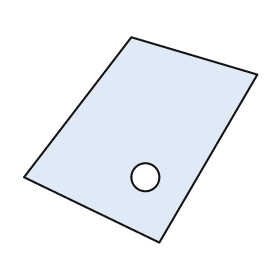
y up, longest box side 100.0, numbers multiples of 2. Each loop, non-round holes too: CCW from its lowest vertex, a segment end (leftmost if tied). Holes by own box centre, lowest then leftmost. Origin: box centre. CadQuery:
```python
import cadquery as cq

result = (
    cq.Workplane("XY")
    .moveTo(8.0, -44.0)
    .lineTo(50.0, 28.0)
    .lineTo(-4.0, 44.0)
    .lineTo(-50.0, -16.0)
    .close()
    .moveTo(2.0, -16.0)
    .circle(6.0)
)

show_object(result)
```